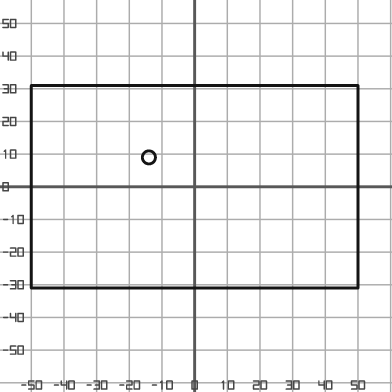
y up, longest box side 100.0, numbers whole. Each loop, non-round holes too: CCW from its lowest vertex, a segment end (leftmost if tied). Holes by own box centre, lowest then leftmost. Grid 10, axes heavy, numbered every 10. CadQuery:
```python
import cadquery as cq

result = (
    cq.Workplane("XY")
    .moveTo(-50.0, -31.0)
    .lineTo(50.0, -31.0)
    .lineTo(50.0, 31.0)
    .lineTo(-50.0, 31.0)
    .close()
    .moveTo(-14.0, 9.0)
    .circle(2.0)
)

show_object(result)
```